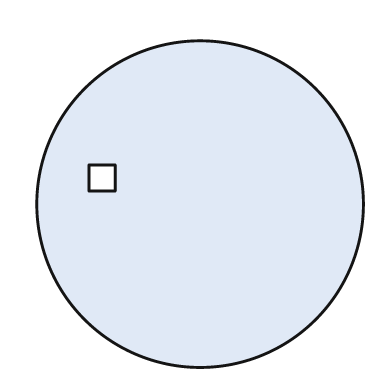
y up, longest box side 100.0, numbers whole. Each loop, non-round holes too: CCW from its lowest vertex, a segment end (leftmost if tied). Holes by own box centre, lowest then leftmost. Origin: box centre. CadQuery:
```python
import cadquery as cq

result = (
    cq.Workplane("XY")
    .moveTo(0.0, 0.0)
    .circle(50.0)
    .moveTo(-34.0, 4.0)
    .lineTo(-26.0, 4.0)
    .lineTo(-26.0, 12.0)
    .lineTo(-34.0, 12.0)
    .close()
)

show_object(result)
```